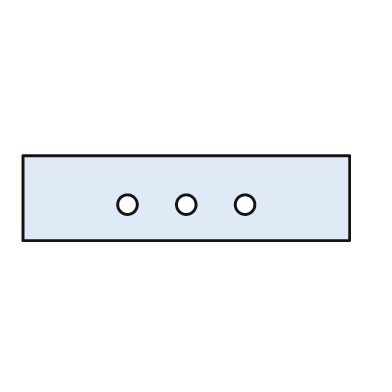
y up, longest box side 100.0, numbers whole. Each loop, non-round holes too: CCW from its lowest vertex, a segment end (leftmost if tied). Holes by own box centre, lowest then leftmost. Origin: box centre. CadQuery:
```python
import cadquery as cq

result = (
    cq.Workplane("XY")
    .moveTo(-50.0, -13.0)
    .lineTo(50.0, -13.0)
    .lineTo(50.0, 13.0)
    .lineTo(-50.0, 13.0)
    .close()
    .moveTo(-18.0, -2.0)
    .circle(3.0)
    .moveTo(0.0, -2.0)
    .circle(3.0)
    .moveTo(18.0, -2.0)
    .circle(3.0)
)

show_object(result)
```